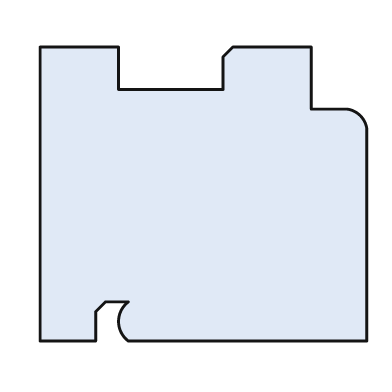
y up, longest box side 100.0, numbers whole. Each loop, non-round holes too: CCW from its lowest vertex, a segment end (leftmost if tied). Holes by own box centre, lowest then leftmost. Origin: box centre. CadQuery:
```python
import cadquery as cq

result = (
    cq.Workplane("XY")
    .moveTo(-50.0, -45.0)
    .lineTo(-33.0, -45.0)
    .lineTo(-33.0, -36.0)
    .lineTo(-30.0, -33.0)
    .lineTo(-23.0, -33.0)
    .threePointArc((-26.0, -39.0), (-23.0, -45.0))
    .lineTo(50.0, -45.0)
    .lineTo(50.0, 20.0)
    .threePointArc((48.0, 24.0), (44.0, 26.0))
    .lineTo(33.0, 26.0)
    .lineTo(33.0, 45.0)
    .lineTo(9.0, 45.0)
    .lineTo(6.0, 42.0)
    .lineTo(6.0, 32.0)
    .lineTo(-26.0, 32.0)
    .lineTo(-26.0, 45.0)
    .lineTo(-50.0, 45.0)
    .close()
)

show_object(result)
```